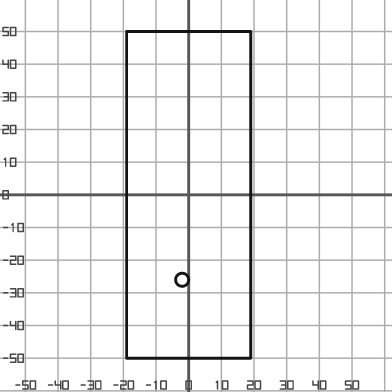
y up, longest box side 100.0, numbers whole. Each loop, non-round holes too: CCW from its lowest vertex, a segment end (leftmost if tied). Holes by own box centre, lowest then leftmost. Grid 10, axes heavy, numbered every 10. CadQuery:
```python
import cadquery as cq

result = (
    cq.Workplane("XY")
    .moveTo(-19.0, -50.0)
    .lineTo(19.0, -50.0)
    .lineTo(19.0, 50.0)
    .lineTo(-19.0, 50.0)
    .close()
    .moveTo(-2.0, -26.0)
    .circle(2.0)
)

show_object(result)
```